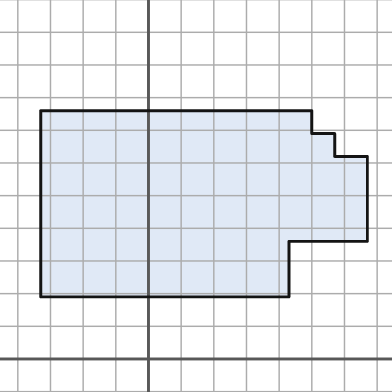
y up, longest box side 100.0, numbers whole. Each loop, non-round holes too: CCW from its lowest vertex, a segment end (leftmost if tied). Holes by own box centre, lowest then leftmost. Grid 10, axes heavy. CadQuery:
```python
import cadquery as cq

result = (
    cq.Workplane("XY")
    .moveTo(-33.0, 19.0)
    .lineTo(43.0, 19.0)
    .lineTo(43.0, 36.0)
    .lineTo(67.0, 36.0)
    .lineTo(67.0, 62.0)
    .lineTo(57.0, 62.0)
    .lineTo(57.0, 69.0)
    .lineTo(50.0, 69.0)
    .lineTo(50.0, 76.0)
    .lineTo(-33.0, 76.0)
    .close()
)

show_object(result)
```